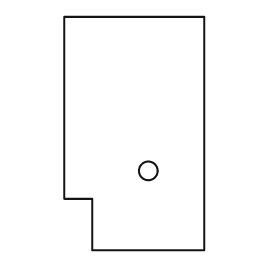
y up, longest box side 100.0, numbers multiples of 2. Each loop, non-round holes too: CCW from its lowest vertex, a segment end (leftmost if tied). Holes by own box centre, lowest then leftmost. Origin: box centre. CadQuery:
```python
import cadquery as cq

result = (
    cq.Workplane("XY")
    .moveTo(-18.0, -50.0)
    .lineTo(30.0, -50.0)
    .lineTo(30.0, 50.0)
    .lineTo(-30.0, 50.0)
    .lineTo(-30.0, -28.0)
    .lineTo(-18.0, -28.0)
    .close()
    .moveTo(6.0, -16.0)
    .circle(4.0)
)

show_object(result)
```